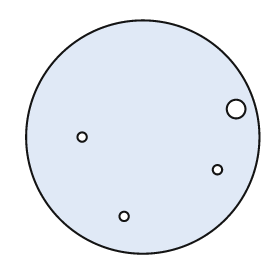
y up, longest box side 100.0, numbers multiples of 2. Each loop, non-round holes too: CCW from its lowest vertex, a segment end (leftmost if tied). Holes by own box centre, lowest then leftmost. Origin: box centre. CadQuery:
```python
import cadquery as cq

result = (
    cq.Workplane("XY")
    .moveTo(0.0, 0.0)
    .circle(50.0)
    .moveTo(-8.0, -34.0)
    .circle(2.0)
    .moveTo(32.0, -14.0)
    .circle(2.0)
    .moveTo(-26.0, 0.0)
    .circle(2.0)
    .moveTo(40.0, 12.0)
    .circle(4.0)
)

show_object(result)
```